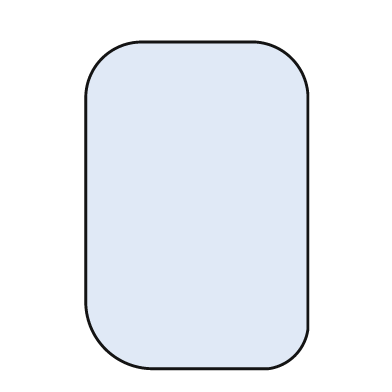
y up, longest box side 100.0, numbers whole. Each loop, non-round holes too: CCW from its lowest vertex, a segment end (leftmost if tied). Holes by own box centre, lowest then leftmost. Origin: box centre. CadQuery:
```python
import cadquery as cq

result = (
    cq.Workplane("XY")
    .moveTo(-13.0, -50.0)
    .lineTo(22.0, -50.0)
    .threePointArc((30.0, -46.0), (34.0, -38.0))
    .lineTo(34.0, 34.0)
    .threePointArc((29.0, 45.0), (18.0, 50.0))
    .lineTo(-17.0, 50.0)
    .threePointArc((-29.0, 45.0), (-34.0, 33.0))
    .lineTo(-34.0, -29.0)
    .threePointArc((-28.0, -44.0), (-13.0, -50.0))
    .close()
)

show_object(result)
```